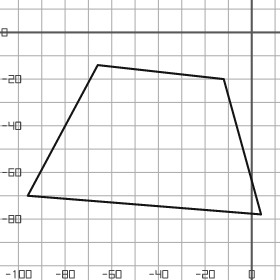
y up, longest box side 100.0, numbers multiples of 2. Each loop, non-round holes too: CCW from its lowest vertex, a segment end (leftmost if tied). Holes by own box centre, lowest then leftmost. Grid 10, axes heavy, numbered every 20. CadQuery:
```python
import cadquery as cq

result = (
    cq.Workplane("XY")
    .moveTo(4.0, -78.0)
    .lineTo(-12.0, -20.0)
    .lineTo(-66.0, -14.0)
    .lineTo(-96.0, -70.0)
    .close()
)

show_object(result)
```